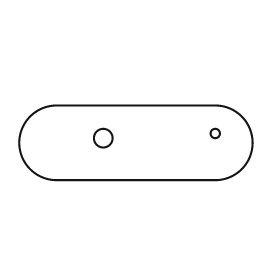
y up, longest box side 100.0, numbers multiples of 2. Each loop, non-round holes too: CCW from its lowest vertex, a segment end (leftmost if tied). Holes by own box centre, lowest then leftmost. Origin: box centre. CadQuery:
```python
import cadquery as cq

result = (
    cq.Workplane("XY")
    .moveTo(-34.0, -16.0)
    .lineTo(34.0, -16.0)
    .threePointArc((50.0, 0.0), (34.0, 16.0))
    .lineTo(-34.0, 16.0)
    .threePointArc((-50.0, 0.0), (-34.0, -16.0))
    .close()
    .moveTo(-14.0, 2.0)
    .circle(4.0)
    .moveTo(34.0, 4.0)
    .circle(2.0)
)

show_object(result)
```